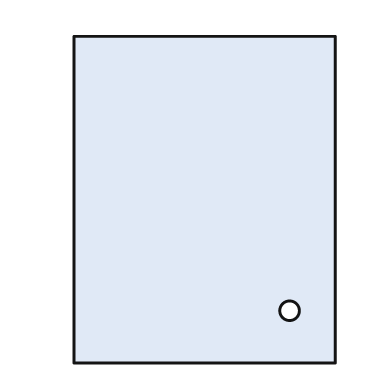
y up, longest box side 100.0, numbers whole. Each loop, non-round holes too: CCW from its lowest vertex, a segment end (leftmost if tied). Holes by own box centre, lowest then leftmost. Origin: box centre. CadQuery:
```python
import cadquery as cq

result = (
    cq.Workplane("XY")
    .moveTo(-40.0, -50.0)
    .lineTo(40.0, -50.0)
    .lineTo(40.0, 50.0)
    .lineTo(-40.0, 50.0)
    .close()
    .moveTo(26.0, -34.0)
    .circle(3.0)
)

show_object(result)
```